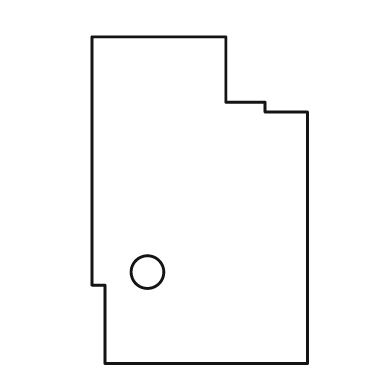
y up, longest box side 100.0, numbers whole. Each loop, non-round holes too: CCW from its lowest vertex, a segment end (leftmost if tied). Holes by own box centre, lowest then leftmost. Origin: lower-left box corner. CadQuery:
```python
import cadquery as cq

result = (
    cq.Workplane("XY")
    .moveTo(4.0, 0.0)
    .lineTo(66.0, 0.0)
    .lineTo(66.0, 77.0)
    .lineTo(53.0, 77.0)
    .lineTo(53.0, 80.0)
    .lineTo(41.0, 80.0)
    .lineTo(41.0, 100.0)
    .lineTo(0.0, 100.0)
    .lineTo(0.0, 24.0)
    .lineTo(4.0, 24.0)
    .close()
    .moveTo(17.0, 28.0)
    .circle(5.0)
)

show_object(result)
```